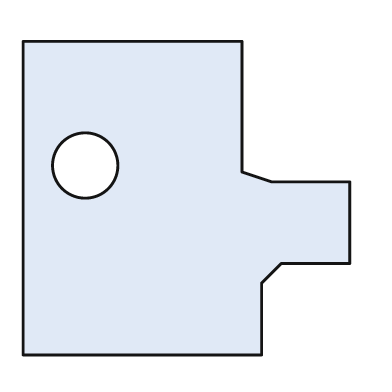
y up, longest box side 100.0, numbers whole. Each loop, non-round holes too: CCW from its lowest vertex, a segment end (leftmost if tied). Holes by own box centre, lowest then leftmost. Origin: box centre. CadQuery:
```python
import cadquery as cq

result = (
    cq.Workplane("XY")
    .moveTo(-50.0, -48.0)
    .lineTo(23.0, -48.0)
    .lineTo(23.0, -26.0)
    .lineTo(29.0, -20.0)
    .lineTo(50.0, -20.0)
    .lineTo(50.0, 5.0)
    .lineTo(26.0, 5.0)
    .lineTo(17.0, 8.0)
    .lineTo(17.0, 48.0)
    .lineTo(-50.0, 48.0)
    .close()
    .moveTo(-31.0, 10.0)
    .circle(10.0)
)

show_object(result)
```